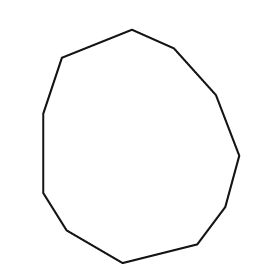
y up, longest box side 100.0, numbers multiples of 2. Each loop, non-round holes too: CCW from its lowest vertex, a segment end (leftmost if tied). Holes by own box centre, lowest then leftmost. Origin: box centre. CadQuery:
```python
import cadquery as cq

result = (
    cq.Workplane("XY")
    .moveTo(-8.0, -50.0)
    .lineTo(24.0, -42.0)
    .lineTo(36.0, -26.0)
    .lineTo(42.0, -4.0)
    .lineTo(32.0, 22.0)
    .lineTo(14.0, 42.0)
    .lineTo(-4.0, 50.0)
    .lineTo(-34.0, 38.0)
    .lineTo(-42.0, 14.0)
    .lineTo(-42.0, -20.0)
    .lineTo(-32.0, -36.0)
    .close()
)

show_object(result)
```